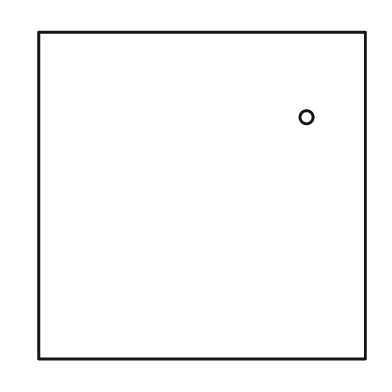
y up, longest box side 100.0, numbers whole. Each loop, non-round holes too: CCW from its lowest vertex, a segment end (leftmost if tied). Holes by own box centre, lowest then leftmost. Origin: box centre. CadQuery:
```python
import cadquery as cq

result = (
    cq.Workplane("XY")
    .moveTo(-50.0, -50.0)
    .lineTo(50.0, -50.0)
    .lineTo(50.0, 50.0)
    .lineTo(-50.0, 50.0)
    .close()
    .moveTo(32.0, 24.0)
    .circle(2.0)
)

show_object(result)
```